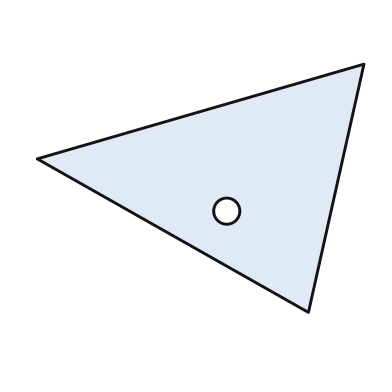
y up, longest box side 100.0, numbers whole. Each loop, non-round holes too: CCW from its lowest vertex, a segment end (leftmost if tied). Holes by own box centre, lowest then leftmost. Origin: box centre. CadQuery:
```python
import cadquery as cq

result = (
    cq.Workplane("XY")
    .moveTo(33.0, -38.0)
    .lineTo(50.0, 38.0)
    .lineTo(-50.0, 9.0)
    .close()
    .moveTo(8.0, -7.0)
    .circle(4.0)
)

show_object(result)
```